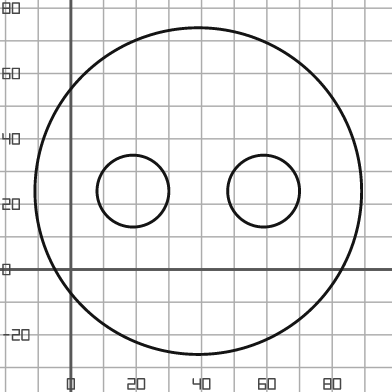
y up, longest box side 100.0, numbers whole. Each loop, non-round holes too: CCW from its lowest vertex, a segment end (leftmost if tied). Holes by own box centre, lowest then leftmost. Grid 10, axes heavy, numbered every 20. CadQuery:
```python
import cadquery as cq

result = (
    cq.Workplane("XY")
    .moveTo(39.0, 24.0)
    .circle(50.0)
    .moveTo(19.0, 24.0)
    .circle(11.0)
    .moveTo(59.0, 24.0)
    .circle(11.0)
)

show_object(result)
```